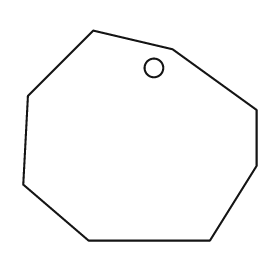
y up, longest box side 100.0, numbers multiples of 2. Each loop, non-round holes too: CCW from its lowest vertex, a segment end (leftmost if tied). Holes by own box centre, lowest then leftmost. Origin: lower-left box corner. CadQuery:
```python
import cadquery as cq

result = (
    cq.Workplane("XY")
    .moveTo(28.0, 0.0)
    .lineTo(80.0, 0.0)
    .lineTo(100.0, 32.0)
    .lineTo(100.0, 56.0)
    .lineTo(64.0, 82.0)
    .lineTo(30.0, 90.0)
    .lineTo(2.0, 62.0)
    .lineTo(0.0, 24.0)
    .close()
    .moveTo(56.0, 74.0)
    .circle(4.0)
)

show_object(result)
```